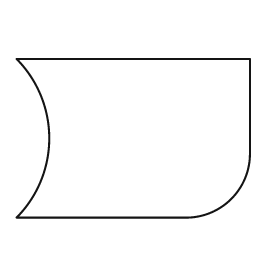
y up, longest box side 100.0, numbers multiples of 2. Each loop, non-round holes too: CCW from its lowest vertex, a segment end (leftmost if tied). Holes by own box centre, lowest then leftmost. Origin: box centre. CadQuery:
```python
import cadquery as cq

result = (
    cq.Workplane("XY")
    .moveTo(-50.0, -34.0)
    .lineTo(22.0, -34.0)
    .threePointArc((42.0, -26.0), (50.0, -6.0))
    .lineTo(50.0, 34.0)
    .lineTo(-50.0, 34.0)
    .threePointArc((-36.0, 0.0), (-50.0, -34.0))
    .close()
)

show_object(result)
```